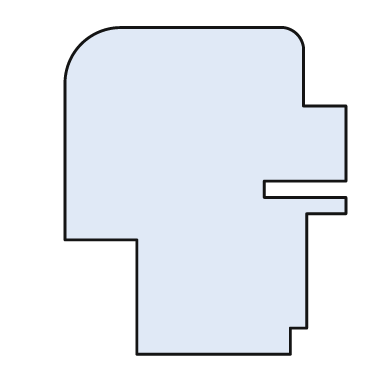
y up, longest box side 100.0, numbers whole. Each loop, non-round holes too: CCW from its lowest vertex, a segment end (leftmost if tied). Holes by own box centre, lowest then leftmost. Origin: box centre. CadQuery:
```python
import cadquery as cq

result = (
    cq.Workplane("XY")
    .moveTo(-21.0, -50.0)
    .lineTo(26.0, -50.0)
    .lineTo(26.0, -42.0)
    .lineTo(31.0, -42.0)
    .lineTo(31.0, -7.0)
    .lineTo(43.0, -7.0)
    .lineTo(43.0, -2.0)
    .lineTo(18.0, -2.0)
    .lineTo(18.0, 3.0)
    .lineTo(43.0, 3.0)
    .lineTo(43.0, 26.0)
    .lineTo(30.0, 26.0)
    .lineTo(30.0, 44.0)
    .threePointArc((28.0, 48.0), (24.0, 50.0))
    .lineTo(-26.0, 50.0)
    .threePointArc((-38.0, 45.0), (-43.0, 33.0))
    .lineTo(-43.0, -15.0)
    .lineTo(-21.0, -15.0)
    .close()
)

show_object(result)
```